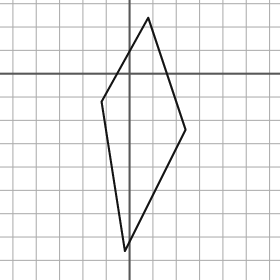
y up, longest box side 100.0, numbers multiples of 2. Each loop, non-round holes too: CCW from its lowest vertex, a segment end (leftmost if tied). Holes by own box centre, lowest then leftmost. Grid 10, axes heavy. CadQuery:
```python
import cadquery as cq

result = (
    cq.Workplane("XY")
    .moveTo(-2.0, -76.0)
    .lineTo(24.0, -24.0)
    .lineTo(8.0, 24.0)
    .lineTo(-12.0, -12.0)
    .close()
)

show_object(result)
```